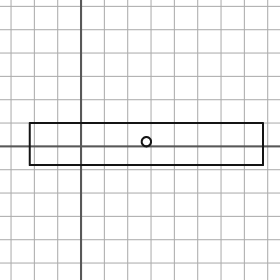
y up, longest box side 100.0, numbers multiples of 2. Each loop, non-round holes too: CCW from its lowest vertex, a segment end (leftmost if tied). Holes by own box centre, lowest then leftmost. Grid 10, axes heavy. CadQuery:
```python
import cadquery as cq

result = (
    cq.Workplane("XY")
    .moveTo(-22.0, -8.0)
    .lineTo(78.0, -8.0)
    .lineTo(78.0, 10.0)
    .lineTo(-22.0, 10.0)
    .close()
    .moveTo(28.0, 2.0)
    .circle(2.0)
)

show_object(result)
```